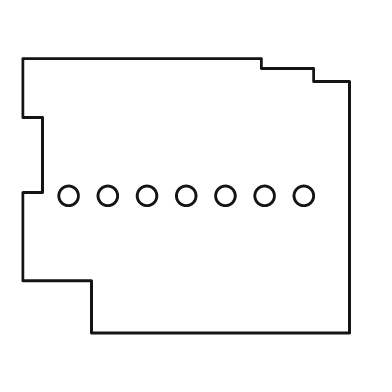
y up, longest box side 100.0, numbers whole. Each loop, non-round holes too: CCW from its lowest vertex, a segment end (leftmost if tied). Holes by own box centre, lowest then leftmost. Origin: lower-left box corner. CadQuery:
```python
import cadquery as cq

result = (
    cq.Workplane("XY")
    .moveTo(21.0, 0.0)
    .lineTo(100.0, 0.0)
    .lineTo(100.0, 77.0)
    .lineTo(89.0, 77.0)
    .lineTo(89.0, 81.0)
    .lineTo(73.0, 81.0)
    .lineTo(73.0, 84.0)
    .lineTo(0.0, 84.0)
    .lineTo(0.0, 66.0)
    .lineTo(6.0, 66.0)
    .lineTo(6.0, 43.0)
    .lineTo(0.0, 43.0)
    .lineTo(0.0, 16.0)
    .lineTo(21.0, 16.0)
    .close()
    .moveTo(14.0, 42.0)
    .circle(3.0)
    .moveTo(26.0, 42.0)
    .circle(3.0)
    .moveTo(38.0, 42.0)
    .circle(3.0)
    .moveTo(50.0, 42.0)
    .circle(3.0)
    .moveTo(62.0, 42.0)
    .circle(3.0)
    .moveTo(74.0, 42.0)
    .circle(3.0)
    .moveTo(86.0, 42.0)
    .circle(3.0)
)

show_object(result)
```